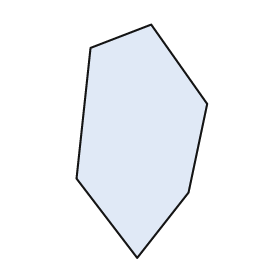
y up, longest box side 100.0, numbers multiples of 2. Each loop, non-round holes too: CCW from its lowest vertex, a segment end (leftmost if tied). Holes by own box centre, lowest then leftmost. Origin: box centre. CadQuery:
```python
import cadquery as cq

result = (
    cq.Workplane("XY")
    .moveTo(-2.0, -50.0)
    .lineTo(20.0, -22.0)
    .lineTo(28.0, 16.0)
    .lineTo(4.0, 50.0)
    .lineTo(-22.0, 40.0)
    .lineTo(-28.0, -16.0)
    .close()
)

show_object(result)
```